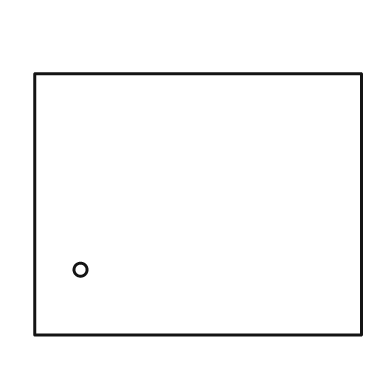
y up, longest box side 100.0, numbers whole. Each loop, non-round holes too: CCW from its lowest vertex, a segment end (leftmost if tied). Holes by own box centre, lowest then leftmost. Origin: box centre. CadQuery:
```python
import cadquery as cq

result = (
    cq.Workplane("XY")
    .moveTo(-50.0, -40.0)
    .lineTo(50.0, -40.0)
    .lineTo(50.0, 40.0)
    .lineTo(-50.0, 40.0)
    .close()
    .moveTo(-36.0, -20.0)
    .circle(2.0)
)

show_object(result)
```